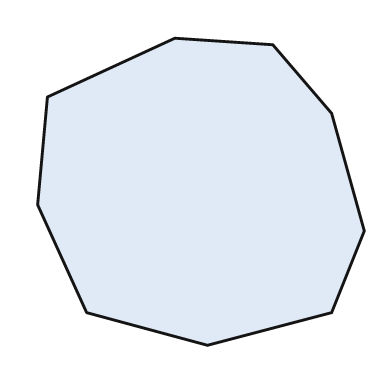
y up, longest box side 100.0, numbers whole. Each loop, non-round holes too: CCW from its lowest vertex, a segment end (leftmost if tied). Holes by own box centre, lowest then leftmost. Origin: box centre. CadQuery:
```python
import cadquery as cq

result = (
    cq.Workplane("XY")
    .moveTo(2.0, -47.0)
    .lineTo(40.0, -37.0)
    .lineTo(50.0, -12.0)
    .lineTo(40.0, 24.0)
    .lineTo(22.0, 45.0)
    .lineTo(-8.0, 47.0)
    .lineTo(-47.0, 29.0)
    .lineTo(-50.0, -4.0)
    .lineTo(-35.0, -37.0)
    .close()
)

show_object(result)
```